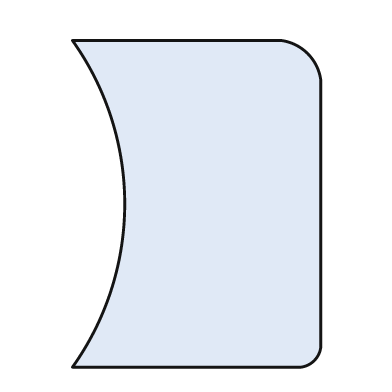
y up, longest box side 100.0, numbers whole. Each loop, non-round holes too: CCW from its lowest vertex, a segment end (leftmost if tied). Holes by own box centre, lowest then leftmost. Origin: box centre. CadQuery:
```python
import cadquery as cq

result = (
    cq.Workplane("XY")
    .moveTo(-38.0, -50.0)
    .lineTo(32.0, -50.0)
    .threePointArc((36.0, -48.0), (38.0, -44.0))
    .lineTo(38.0, 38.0)
    .threePointArc((34.0, 46.0), (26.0, 50.0))
    .lineTo(-38.0, 50.0)
    .threePointArc((-22.0, 0.0), (-38.0, -50.0))
    .close()
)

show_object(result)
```